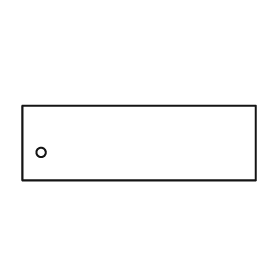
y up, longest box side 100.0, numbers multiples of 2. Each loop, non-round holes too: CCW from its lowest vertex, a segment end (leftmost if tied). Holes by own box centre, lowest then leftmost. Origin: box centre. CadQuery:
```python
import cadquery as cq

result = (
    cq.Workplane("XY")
    .moveTo(-50.0, -16.0)
    .lineTo(50.0, -16.0)
    .lineTo(50.0, 16.0)
    .lineTo(-50.0, 16.0)
    .close()
    .moveTo(-42.0, -4.0)
    .circle(2.0)
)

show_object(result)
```